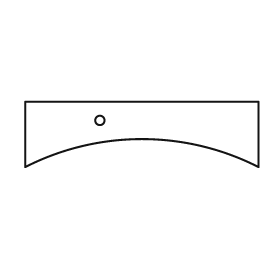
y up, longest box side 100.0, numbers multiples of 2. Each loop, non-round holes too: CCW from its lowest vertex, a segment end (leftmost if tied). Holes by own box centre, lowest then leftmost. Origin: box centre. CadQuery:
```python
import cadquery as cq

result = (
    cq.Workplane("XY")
    .moveTo(-50.0, -14.0)
    .threePointArc((0.0, -2.0), (50.0, -14.0))
    .lineTo(50.0, 14.0)
    .lineTo(-50.0, 14.0)
    .close()
    .moveTo(-18.0, 6.0)
    .circle(2.0)
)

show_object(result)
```